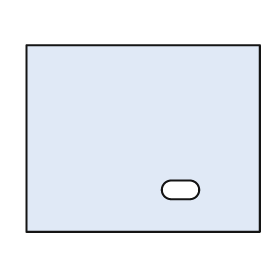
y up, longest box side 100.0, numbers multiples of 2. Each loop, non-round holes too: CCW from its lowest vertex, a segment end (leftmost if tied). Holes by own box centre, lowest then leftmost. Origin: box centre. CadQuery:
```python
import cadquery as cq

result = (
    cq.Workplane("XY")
    .moveTo(-50.0, -40.0)
    .lineTo(50.0, -40.0)
    .lineTo(50.0, 40.0)
    .lineTo(-50.0, 40.0)
    .close()
    .moveTo(12.0, -26.0)
    .lineTo(20.0, -26.0)
    .threePointArc((24.0, -22.0), (20.0, -18.0))
    .lineTo(12.0, -18.0)
    .threePointArc((8.0, -22.0), (12.0, -26.0))
    .close()
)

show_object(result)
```